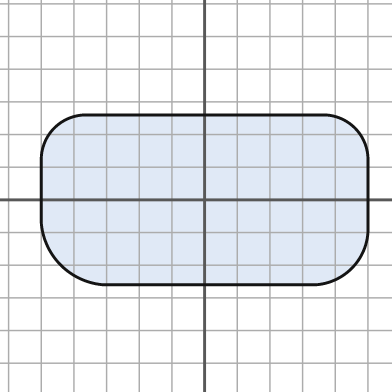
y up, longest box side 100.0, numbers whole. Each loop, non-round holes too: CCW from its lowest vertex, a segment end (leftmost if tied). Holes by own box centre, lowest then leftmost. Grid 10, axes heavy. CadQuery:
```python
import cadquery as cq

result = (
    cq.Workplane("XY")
    .moveTo(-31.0, -26.0)
    .lineTo(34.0, -26.0)
    .threePointArc((45.0, -21.0), (50.0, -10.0))
    .lineTo(50.0, 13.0)
    .threePointArc((46.0, 22.0), (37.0, 26.0))
    .lineTo(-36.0, 26.0)
    .threePointArc((-46.0, 22.0), (-50.0, 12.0))
    .lineTo(-50.0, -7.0)
    .threePointArc((-44.0, -20.0), (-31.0, -26.0))
    .close()
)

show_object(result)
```